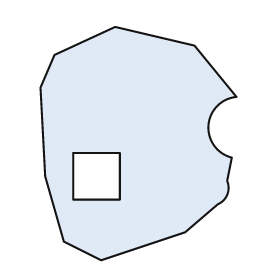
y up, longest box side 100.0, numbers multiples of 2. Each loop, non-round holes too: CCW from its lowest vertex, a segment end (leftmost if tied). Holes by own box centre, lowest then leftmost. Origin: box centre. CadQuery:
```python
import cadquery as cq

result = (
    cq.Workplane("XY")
    .moveTo(-16.0, -50.0)
    .lineTo(20.0, -38.0)
    .lineTo(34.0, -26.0)
    .threePointArc((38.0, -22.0), (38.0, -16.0))
    .lineTo(40.0, -6.0)
    .threePointArc((30.0, 8.0), (42.0, 20.0))
    .lineTo(24.0, 42.0)
    .lineTo(-10.0, 50.0)
    .lineTo(-36.0, 38.0)
    .lineTo(-42.0, 24.0)
    .lineTo(-40.0, -14.0)
    .lineTo(-32.0, -42.0)
    .close()
    .moveTo(-28.0, -24.0)
    .lineTo(-8.0, -24.0)
    .lineTo(-8.0, -4.0)
    .lineTo(-28.0, -4.0)
    .close()
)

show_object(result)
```